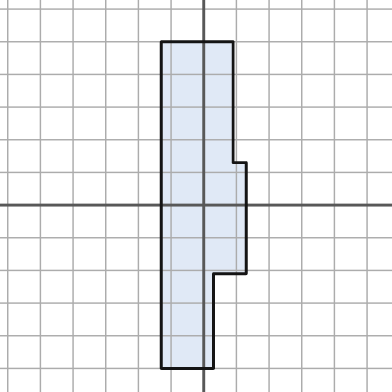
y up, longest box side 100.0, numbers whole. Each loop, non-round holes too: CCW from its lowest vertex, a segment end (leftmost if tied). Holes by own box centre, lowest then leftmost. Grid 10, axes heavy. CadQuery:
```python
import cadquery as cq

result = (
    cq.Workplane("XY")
    .moveTo(-13.0, -50.0)
    .lineTo(3.0, -50.0)
    .lineTo(3.0, -21.0)
    .lineTo(13.0, -21.0)
    .lineTo(13.0, 13.0)
    .lineTo(9.0, 13.0)
    .lineTo(9.0, 50.0)
    .lineTo(-13.0, 50.0)
    .close()
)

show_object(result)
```